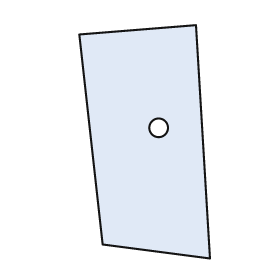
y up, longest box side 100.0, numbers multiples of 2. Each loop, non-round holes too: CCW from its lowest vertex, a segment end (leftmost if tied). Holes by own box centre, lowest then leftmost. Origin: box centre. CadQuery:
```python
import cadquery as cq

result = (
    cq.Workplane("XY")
    .moveTo(28.0, -50.0)
    .lineTo(22.0, 50.0)
    .lineTo(-28.0, 46.0)
    .lineTo(-18.0, -44.0)
    .close()
    .moveTo(6.0, 6.0)
    .circle(4.0)
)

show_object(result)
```